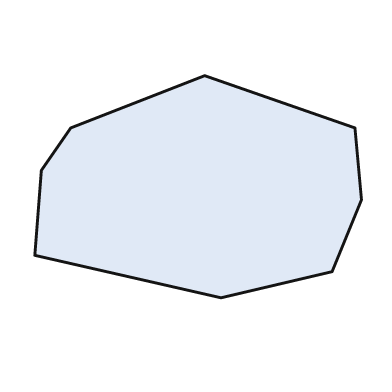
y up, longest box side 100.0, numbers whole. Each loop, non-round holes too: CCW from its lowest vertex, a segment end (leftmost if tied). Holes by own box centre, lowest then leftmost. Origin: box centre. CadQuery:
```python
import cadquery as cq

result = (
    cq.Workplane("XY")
    .moveTo(7.0, -34.0)
    .lineTo(41.0, -26.0)
    .lineTo(50.0, -4.0)
    .lineTo(48.0, 18.0)
    .lineTo(2.0, 34.0)
    .lineTo(-39.0, 18.0)
    .lineTo(-48.0, 5.0)
    .lineTo(-50.0, -21.0)
    .close()
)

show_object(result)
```